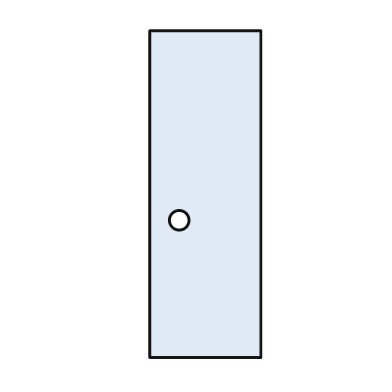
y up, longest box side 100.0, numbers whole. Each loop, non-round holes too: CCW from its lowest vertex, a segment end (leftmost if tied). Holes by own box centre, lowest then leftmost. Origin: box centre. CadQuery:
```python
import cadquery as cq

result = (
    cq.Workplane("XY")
    .moveTo(-17.0, -50.0)
    .lineTo(17.0, -50.0)
    .lineTo(17.0, 50.0)
    .lineTo(-17.0, 50.0)
    .close()
    .moveTo(-8.0, -8.0)
    .circle(3.0)
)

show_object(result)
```